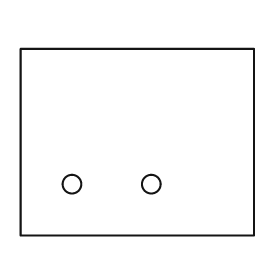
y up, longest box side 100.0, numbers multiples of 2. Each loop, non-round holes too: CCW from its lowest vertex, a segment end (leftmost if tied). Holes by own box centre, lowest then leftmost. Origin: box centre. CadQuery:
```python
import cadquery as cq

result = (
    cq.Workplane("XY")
    .moveTo(-50.0, -40.0)
    .lineTo(50.0, -40.0)
    .lineTo(50.0, 40.0)
    .lineTo(-50.0, 40.0)
    .close()
    .moveTo(-28.0, -18.0)
    .circle(4.0)
    .moveTo(6.0, -18.0)
    .circle(4.0)
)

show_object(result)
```